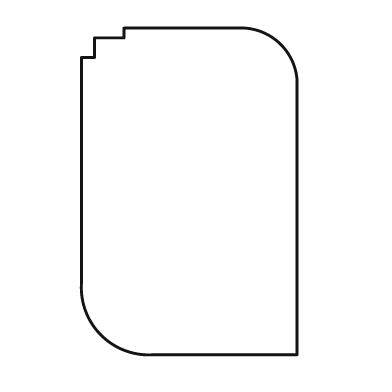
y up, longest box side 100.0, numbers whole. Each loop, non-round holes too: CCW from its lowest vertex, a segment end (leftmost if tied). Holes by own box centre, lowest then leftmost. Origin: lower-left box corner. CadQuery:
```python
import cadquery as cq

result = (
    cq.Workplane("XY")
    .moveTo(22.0, 0.0)
    .lineTo(66.0, 0.0)
    .lineTo(66.0, 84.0)
    .threePointArc((61.0, 95.0), (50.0, 100.0))
    .lineTo(13.0, 100.0)
    .lineTo(13.0, 97.0)
    .lineTo(4.0, 97.0)
    .lineTo(4.0, 91.0)
    .lineTo(0.0, 91.0)
    .lineTo(0.0, 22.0)
    .threePointArc((6.0, 6.0), (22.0, 0.0))
    .close()
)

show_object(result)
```